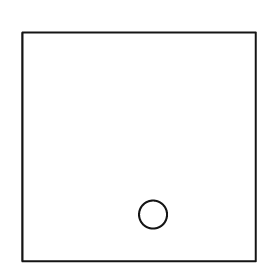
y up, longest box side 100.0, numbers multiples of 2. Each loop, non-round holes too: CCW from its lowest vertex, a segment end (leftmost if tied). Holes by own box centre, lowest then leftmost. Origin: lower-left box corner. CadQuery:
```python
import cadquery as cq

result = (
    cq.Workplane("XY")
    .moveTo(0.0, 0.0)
    .lineTo(100.0, 0.0)
    .lineTo(100.0, 98.0)
    .lineTo(0.0, 98.0)
    .close()
    .moveTo(56.0, 20.0)
    .circle(6.0)
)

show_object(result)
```